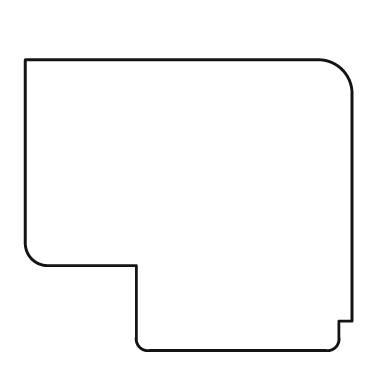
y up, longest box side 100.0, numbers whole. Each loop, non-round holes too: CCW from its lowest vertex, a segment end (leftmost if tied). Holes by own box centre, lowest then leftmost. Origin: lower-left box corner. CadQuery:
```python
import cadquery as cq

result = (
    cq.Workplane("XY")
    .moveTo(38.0, 0.0)
    .lineTo(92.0, 0.0)
    .threePointArc((95.0, 1.0), (96.0, 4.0))
    .lineTo(96.0, 9.0)
    .lineTo(100.0, 9.0)
    .lineTo(100.0, 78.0)
    .threePointArc((97.0, 86.0), (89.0, 89.0))
    .lineTo(0.0, 89.0)
    .lineTo(0.0, 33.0)
    .threePointArc((2.0, 28.0), (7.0, 26.0))
    .lineTo(34.0, 26.0)
    .lineTo(34.0, 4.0)
    .threePointArc((35.0, 1.0), (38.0, 0.0))
    .close()
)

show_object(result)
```